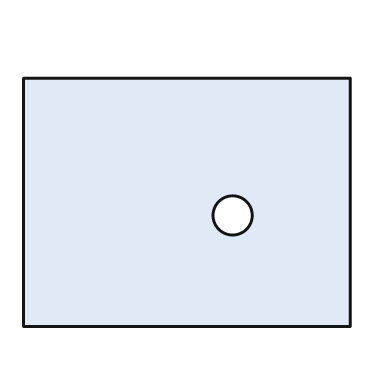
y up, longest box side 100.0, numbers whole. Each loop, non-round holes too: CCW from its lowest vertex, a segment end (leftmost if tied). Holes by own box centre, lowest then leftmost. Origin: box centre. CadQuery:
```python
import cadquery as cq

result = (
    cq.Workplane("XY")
    .moveTo(-50.0, -38.0)
    .lineTo(50.0, -38.0)
    .lineTo(50.0, 38.0)
    .lineTo(-50.0, 38.0)
    .close()
    .moveTo(14.0, -4.0)
    .circle(6.0)
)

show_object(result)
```